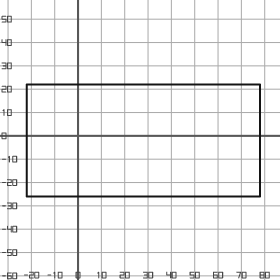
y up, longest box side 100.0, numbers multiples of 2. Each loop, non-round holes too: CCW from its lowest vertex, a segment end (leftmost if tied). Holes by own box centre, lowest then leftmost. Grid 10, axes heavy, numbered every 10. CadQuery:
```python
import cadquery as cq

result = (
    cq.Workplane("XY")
    .moveTo(-22.0, -26.0)
    .lineTo(78.0, -26.0)
    .lineTo(78.0, 22.0)
    .lineTo(-22.0, 22.0)
    .close()
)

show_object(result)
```